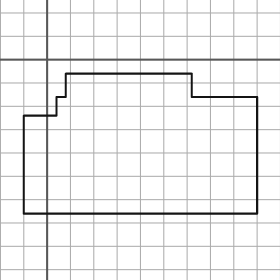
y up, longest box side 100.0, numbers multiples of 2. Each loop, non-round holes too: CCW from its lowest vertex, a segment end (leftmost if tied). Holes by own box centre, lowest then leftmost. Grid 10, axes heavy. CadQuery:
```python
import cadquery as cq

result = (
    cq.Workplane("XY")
    .moveTo(-10.0, -66.0)
    .lineTo(90.0, -66.0)
    .lineTo(90.0, -16.0)
    .lineTo(62.0, -16.0)
    .lineTo(62.0, -6.0)
    .lineTo(8.0, -6.0)
    .lineTo(8.0, -16.0)
    .lineTo(4.0, -16.0)
    .lineTo(4.0, -24.0)
    .lineTo(-10.0, -24.0)
    .close()
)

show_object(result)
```